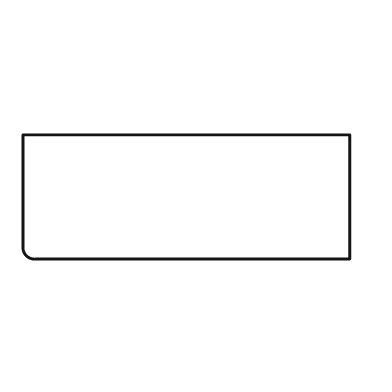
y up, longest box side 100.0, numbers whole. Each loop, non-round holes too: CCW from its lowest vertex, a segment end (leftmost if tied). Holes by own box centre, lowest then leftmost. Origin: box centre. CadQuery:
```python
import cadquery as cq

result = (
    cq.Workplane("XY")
    .moveTo(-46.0, -19.0)
    .lineTo(50.0, -19.0)
    .lineTo(50.0, 19.0)
    .lineTo(-50.0, 19.0)
    .lineTo(-50.0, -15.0)
    .threePointArc((-49.0, -18.0), (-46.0, -19.0))
    .close()
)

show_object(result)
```